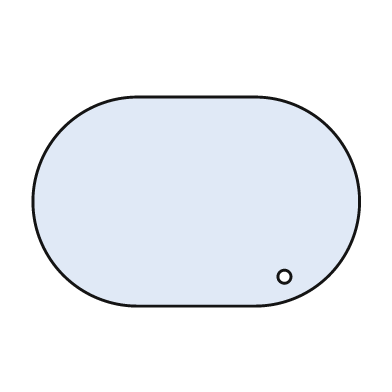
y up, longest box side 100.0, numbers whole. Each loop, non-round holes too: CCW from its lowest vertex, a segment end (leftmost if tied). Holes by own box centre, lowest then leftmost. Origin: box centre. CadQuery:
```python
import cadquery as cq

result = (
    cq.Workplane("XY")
    .moveTo(-18.0, -32.0)
    .lineTo(18.0, -32.0)
    .threePointArc((50.0, 0.0), (18.0, 32.0))
    .lineTo(-18.0, 32.0)
    .threePointArc((-50.0, 0.0), (-18.0, -32.0))
    .close()
    .moveTo(27.0, -23.0)
    .circle(2.0)
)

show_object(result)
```